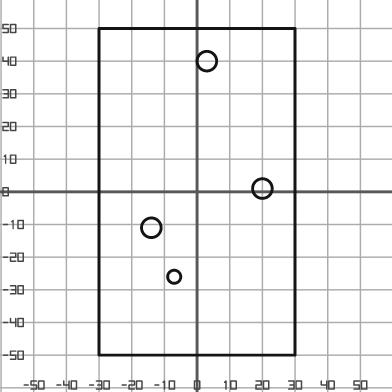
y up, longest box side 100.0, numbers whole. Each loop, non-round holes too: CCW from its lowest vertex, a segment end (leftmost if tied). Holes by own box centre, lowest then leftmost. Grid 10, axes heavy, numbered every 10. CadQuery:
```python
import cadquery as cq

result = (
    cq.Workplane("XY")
    .moveTo(-30.0, -50.0)
    .lineTo(30.0, -50.0)
    .lineTo(30.0, 50.0)
    .lineTo(-30.0, 50.0)
    .close()
    .moveTo(-7.0, -26.0)
    .circle(2.0)
    .moveTo(-14.0, -11.0)
    .circle(3.0)
    .moveTo(20.0, 1.0)
    .circle(3.0)
    .moveTo(3.0, 40.0)
    .circle(3.0)
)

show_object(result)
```